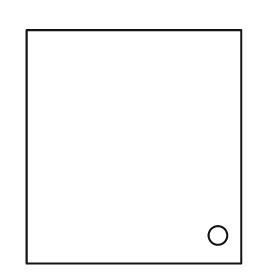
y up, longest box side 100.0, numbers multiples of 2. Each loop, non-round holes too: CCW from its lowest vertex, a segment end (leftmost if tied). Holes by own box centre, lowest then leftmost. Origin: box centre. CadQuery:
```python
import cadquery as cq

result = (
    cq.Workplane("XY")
    .moveTo(-46.0, -50.0)
    .lineTo(46.0, -50.0)
    .lineTo(46.0, 50.0)
    .lineTo(-46.0, 50.0)
    .close()
    .moveTo(36.0, -38.0)
    .circle(4.0)
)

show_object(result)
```